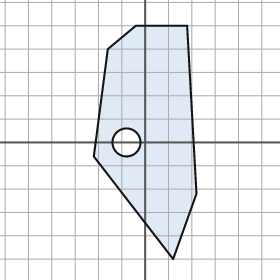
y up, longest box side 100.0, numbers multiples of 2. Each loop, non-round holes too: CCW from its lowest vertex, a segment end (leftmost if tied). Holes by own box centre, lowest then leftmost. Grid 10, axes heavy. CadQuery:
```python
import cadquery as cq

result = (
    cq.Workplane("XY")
    .moveTo(12.0, -50.0)
    .lineTo(22.0, -22.0)
    .lineTo(18.0, 50.0)
    .lineTo(-4.0, 50.0)
    .lineTo(-16.0, 40.0)
    .lineTo(-22.0, -6.0)
    .close()
    .moveTo(-8.0, 0.0)
    .circle(6.0)
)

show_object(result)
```